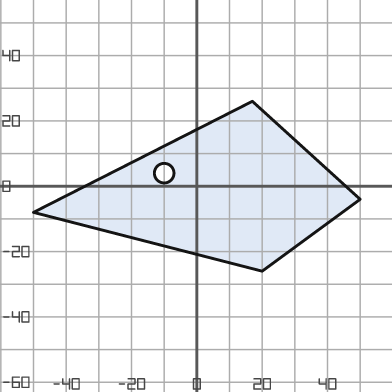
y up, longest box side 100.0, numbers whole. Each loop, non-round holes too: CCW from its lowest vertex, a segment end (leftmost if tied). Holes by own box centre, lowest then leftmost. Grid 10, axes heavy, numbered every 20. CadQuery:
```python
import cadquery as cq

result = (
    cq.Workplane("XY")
    .moveTo(20.0, -26.0)
    .lineTo(50.0, -4.0)
    .lineTo(17.0, 26.0)
    .lineTo(-50.0, -8.0)
    .close()
    .moveTo(-10.0, 4.0)
    .circle(3.0)
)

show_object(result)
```